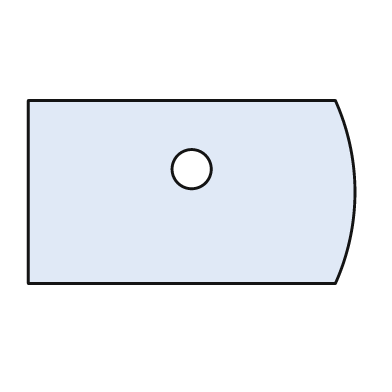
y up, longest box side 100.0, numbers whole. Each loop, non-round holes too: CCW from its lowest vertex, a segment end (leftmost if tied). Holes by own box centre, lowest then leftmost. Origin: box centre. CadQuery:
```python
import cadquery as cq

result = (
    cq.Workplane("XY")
    .moveTo(-50.0, -28.0)
    .lineTo(44.0, -28.0)
    .threePointArc((50.0, 0.0), (44.0, 28.0))
    .lineTo(-50.0, 28.0)
    .close()
    .moveTo(0.0, 7.0)
    .circle(6.0)
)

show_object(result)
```